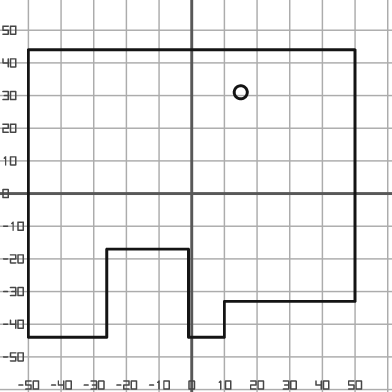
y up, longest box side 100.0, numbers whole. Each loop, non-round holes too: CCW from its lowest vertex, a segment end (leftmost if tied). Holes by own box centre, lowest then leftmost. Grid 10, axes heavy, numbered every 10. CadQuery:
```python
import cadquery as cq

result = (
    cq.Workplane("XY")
    .moveTo(-50.0, -44.0)
    .lineTo(-26.0, -44.0)
    .lineTo(-26.0, -17.0)
    .lineTo(-1.0, -17.0)
    .lineTo(-1.0, -44.0)
    .lineTo(10.0, -44.0)
    .lineTo(10.0, -33.0)
    .lineTo(50.0, -33.0)
    .lineTo(50.0, 44.0)
    .lineTo(-50.0, 44.0)
    .close()
    .moveTo(15.0, 31.0)
    .circle(2.0)
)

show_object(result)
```